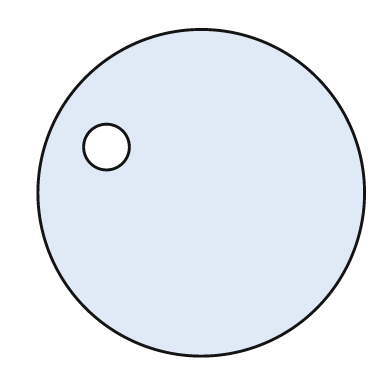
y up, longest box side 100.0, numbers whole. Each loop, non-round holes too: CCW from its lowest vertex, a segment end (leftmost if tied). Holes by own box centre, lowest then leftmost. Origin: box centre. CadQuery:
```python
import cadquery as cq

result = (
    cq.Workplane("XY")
    .moveTo(0.0, 0.0)
    .circle(50.0)
    .moveTo(-29.0, 14.0)
    .circle(7.0)
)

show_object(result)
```